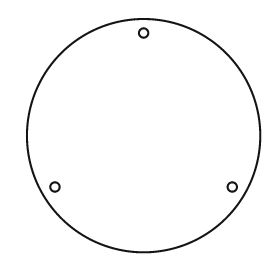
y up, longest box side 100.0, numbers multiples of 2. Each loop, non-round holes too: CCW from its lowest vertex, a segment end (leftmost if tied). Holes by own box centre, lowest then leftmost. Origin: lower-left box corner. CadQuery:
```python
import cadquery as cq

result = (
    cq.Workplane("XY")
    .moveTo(50.0, 50.0)
    .circle(50.0)
    .moveTo(12.0, 28.0)
    .circle(2.0)
    .moveTo(88.0, 28.0)
    .circle(2.0)
    .moveTo(50.0, 94.0)
    .circle(2.0)
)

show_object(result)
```